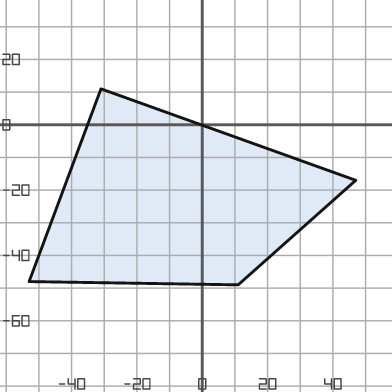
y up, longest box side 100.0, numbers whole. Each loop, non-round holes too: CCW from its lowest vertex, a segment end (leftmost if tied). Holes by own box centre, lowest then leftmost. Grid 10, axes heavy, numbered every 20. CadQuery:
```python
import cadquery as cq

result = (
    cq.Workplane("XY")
    .moveTo(11.0, -49.0)
    .lineTo(47.0, -17.0)
    .lineTo(-31.0, 11.0)
    .lineTo(-53.0, -48.0)
    .close()
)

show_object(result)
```